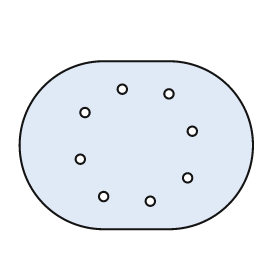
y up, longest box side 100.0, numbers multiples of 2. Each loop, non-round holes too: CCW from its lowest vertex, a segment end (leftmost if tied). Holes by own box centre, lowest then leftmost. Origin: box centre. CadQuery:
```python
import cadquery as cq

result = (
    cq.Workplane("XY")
    .moveTo(-14.0, -36.0)
    .lineTo(14.0, -36.0)
    .threePointArc((50.0, 0.0), (14.0, 36.0))
    .lineTo(-14.0, 36.0)
    .threePointArc((-50.0, 0.0), (-14.0, -36.0))
    .close()
    .moveTo(6.0, -24.0)
    .circle(2.0)
    .moveTo(-14.0, -22.0)
    .circle(2.0)
    .moveTo(22.0, -14.0)
    .circle(2.0)
    .moveTo(-24.0, -6.0)
    .circle(2.0)
    .moveTo(24.0, 6.0)
    .circle(2.0)
    .moveTo(-22.0, 14.0)
    .circle(2.0)
    .moveTo(14.0, 22.0)
    .circle(2.0)
    .moveTo(-6.0, 24.0)
    .circle(2.0)
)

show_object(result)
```